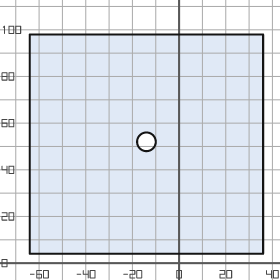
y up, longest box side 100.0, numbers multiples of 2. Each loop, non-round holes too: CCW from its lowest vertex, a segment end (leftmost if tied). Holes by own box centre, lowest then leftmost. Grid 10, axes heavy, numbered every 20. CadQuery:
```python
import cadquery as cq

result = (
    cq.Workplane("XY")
    .moveTo(-64.0, 4.0)
    .lineTo(36.0, 4.0)
    .lineTo(36.0, 98.0)
    .lineTo(-64.0, 98.0)
    .close()
    .moveTo(-14.0, 52.0)
    .circle(4.0)
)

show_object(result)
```